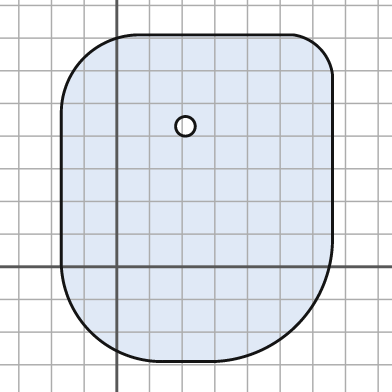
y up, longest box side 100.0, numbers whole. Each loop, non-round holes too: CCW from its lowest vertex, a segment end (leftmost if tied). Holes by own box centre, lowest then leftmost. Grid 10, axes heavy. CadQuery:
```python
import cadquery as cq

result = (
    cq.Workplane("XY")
    .moveTo(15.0, -29.0)
    .lineTo(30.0, -29.0)
    .threePointArc((55.0, -18.0), (66.0, 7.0))
    .lineTo(66.0, 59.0)
    .threePointArc((62.0, 67.0), (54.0, 71.0))
    .lineTo(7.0, 71.0)
    .threePointArc((-10.0, 64.0), (-17.0, 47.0))
    .lineTo(-17.0, 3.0)
    .threePointArc((-8.0, -20.0), (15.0, -29.0))
    .close()
    .moveTo(21.0, 43.0)
    .circle(3.0)
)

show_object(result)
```